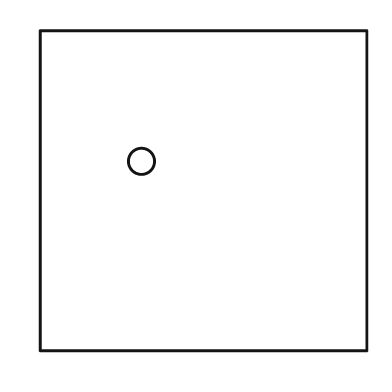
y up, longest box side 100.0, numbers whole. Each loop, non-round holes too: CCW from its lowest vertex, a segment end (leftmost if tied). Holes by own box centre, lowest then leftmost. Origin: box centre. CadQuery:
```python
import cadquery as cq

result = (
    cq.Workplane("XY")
    .moveTo(-50.0, -49.0)
    .lineTo(50.0, -49.0)
    .lineTo(50.0, 49.0)
    .lineTo(-50.0, 49.0)
    .close()
    .moveTo(-19.0, 9.0)
    .circle(4.0)
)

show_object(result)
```